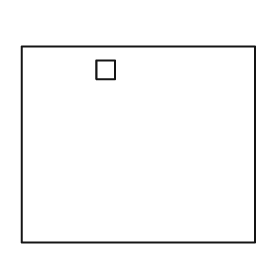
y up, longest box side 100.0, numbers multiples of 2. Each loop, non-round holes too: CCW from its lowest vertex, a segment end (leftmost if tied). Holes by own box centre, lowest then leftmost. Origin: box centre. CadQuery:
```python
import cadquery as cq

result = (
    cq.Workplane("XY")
    .moveTo(-50.0, -42.0)
    .lineTo(50.0, -42.0)
    .lineTo(50.0, 42.0)
    .lineTo(-50.0, 42.0)
    .close()
    .moveTo(-18.0, 28.0)
    .lineTo(-10.0, 28.0)
    .lineTo(-10.0, 36.0)
    .lineTo(-18.0, 36.0)
    .close()
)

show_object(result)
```